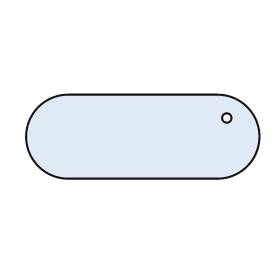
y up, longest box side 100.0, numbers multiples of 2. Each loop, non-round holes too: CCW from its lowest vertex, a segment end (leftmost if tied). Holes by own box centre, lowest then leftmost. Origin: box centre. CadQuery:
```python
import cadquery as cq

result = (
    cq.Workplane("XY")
    .moveTo(-32.0, -18.0)
    .lineTo(32.0, -18.0)
    .threePointArc((50.0, 0.0), (32.0, 18.0))
    .lineTo(-32.0, 18.0)
    .threePointArc((-50.0, 0.0), (-32.0, -18.0))
    .close()
    .moveTo(36.0, 8.0)
    .circle(2.0)
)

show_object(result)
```